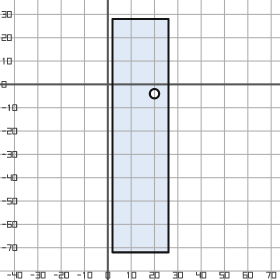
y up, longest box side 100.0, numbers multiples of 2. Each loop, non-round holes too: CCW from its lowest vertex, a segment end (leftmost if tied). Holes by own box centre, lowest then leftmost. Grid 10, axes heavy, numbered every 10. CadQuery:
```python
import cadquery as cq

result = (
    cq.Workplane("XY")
    .moveTo(2.0, -72.0)
    .lineTo(26.0, -72.0)
    .lineTo(26.0, 28.0)
    .lineTo(2.0, 28.0)
    .close()
    .moveTo(20.0, -4.0)
    .circle(2.0)
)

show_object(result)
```